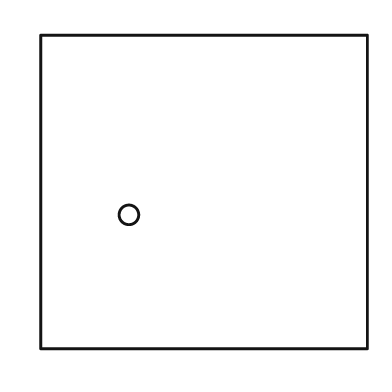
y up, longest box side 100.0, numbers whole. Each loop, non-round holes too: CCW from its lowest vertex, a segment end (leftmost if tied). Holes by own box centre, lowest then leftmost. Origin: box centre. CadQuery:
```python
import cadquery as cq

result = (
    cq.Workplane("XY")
    .moveTo(-50.0, -48.0)
    .lineTo(50.0, -48.0)
    .lineTo(50.0, 48.0)
    .lineTo(-50.0, 48.0)
    .close()
    .moveTo(-23.0, -7.0)
    .circle(3.0)
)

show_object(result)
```